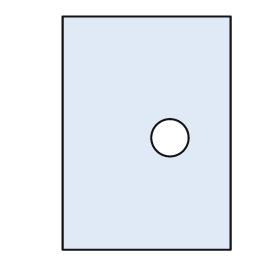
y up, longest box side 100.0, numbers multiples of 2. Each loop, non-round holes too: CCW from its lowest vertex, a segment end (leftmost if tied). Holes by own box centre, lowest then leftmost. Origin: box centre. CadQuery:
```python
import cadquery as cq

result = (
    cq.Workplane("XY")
    .moveTo(-36.0, -50.0)
    .lineTo(36.0, -50.0)
    .lineTo(36.0, 50.0)
    .lineTo(-36.0, 50.0)
    .close()
    .moveTo(10.0, -2.0)
    .circle(8.0)
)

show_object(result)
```